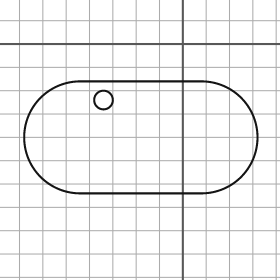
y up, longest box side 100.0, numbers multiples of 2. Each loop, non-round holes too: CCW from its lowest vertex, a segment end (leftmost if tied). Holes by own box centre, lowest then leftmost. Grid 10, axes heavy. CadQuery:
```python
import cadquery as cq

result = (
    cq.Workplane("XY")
    .moveTo(-44.0, -64.0)
    .lineTo(8.0, -64.0)
    .threePointArc((32.0, -40.0), (8.0, -16.0))
    .lineTo(-44.0, -16.0)
    .threePointArc((-68.0, -40.0), (-44.0, -64.0))
    .close()
    .moveTo(-34.0, -24.0)
    .circle(4.0)
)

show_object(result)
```